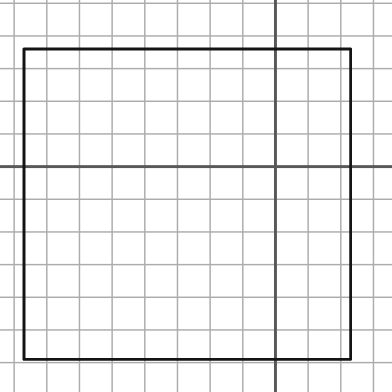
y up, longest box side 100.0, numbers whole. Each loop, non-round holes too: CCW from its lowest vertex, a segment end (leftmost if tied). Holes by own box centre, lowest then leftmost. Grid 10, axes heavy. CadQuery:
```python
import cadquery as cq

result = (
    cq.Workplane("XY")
    .moveTo(-77.0, -59.0)
    .lineTo(23.0, -59.0)
    .lineTo(23.0, 36.0)
    .lineTo(-77.0, 36.0)
    .close()
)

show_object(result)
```